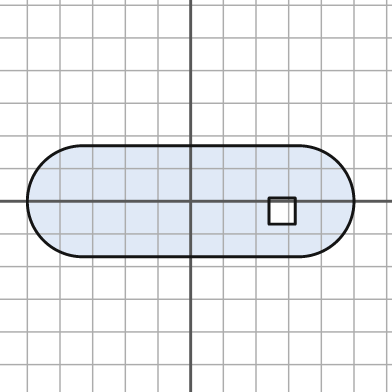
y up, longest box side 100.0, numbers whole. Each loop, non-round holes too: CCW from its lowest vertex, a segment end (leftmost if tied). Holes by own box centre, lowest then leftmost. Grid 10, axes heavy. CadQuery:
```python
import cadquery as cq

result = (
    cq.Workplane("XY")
    .moveTo(-33.0, -17.0)
    .lineTo(33.0, -17.0)
    .threePointArc((50.0, 0.0), (33.0, 17.0))
    .lineTo(-33.0, 17.0)
    .threePointArc((-50.0, 0.0), (-33.0, -17.0))
    .close()
    .moveTo(24.0, -7.0)
    .lineTo(32.0, -7.0)
    .lineTo(32.0, 1.0)
    .lineTo(24.0, 1.0)
    .close()
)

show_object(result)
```